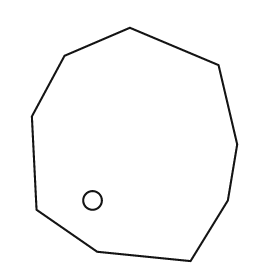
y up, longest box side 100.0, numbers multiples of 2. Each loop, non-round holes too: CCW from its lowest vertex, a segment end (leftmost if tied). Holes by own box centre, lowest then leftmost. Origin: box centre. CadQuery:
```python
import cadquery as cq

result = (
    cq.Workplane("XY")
    .moveTo(24.0, -50.0)
    .lineTo(40.0, -24.0)
    .lineTo(44.0, 0.0)
    .lineTo(36.0, 34.0)
    .lineTo(-2.0, 50.0)
    .lineTo(-30.0, 38.0)
    .lineTo(-44.0, 12.0)
    .lineTo(-42.0, -28.0)
    .lineTo(-16.0, -46.0)
    .close()
    .moveTo(-18.0, -24.0)
    .circle(4.0)
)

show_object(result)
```